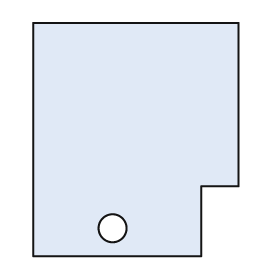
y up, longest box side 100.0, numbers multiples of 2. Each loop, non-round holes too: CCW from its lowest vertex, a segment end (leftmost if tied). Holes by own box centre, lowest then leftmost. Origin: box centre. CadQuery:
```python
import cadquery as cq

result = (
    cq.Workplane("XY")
    .moveTo(-44.0, -50.0)
    .lineTo(28.0, -50.0)
    .lineTo(28.0, -20.0)
    .lineTo(44.0, -20.0)
    .lineTo(44.0, 50.0)
    .lineTo(-44.0, 50.0)
    .close()
    .moveTo(-10.0, -38.0)
    .circle(6.0)
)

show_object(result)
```